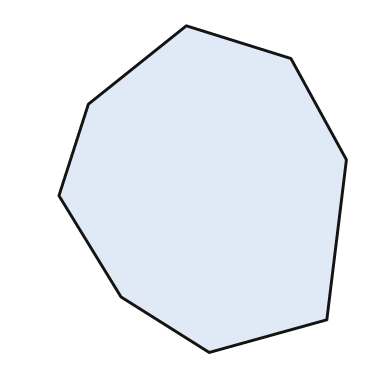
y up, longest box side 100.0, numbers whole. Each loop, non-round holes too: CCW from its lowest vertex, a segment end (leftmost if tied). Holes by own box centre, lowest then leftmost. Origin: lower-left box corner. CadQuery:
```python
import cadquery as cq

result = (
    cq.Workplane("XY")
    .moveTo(46.0, 0.0)
    .lineTo(82.0, 10.0)
    .lineTo(88.0, 59.0)
    .lineTo(71.0, 90.0)
    .lineTo(39.0, 100.0)
    .lineTo(9.0, 76.0)
    .lineTo(0.0, 48.0)
    .lineTo(19.0, 17.0)
    .close()
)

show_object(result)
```